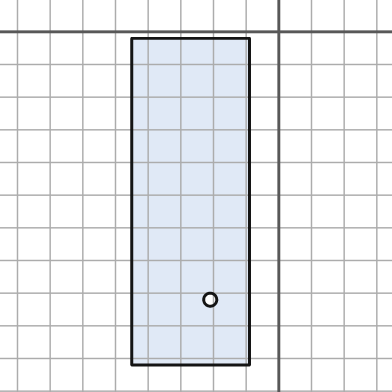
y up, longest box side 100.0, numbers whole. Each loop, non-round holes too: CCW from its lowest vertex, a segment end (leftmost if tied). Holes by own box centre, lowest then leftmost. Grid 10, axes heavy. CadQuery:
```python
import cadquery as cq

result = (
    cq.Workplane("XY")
    .moveTo(-45.0, -102.0)
    .lineTo(-9.0, -102.0)
    .lineTo(-9.0, -2.0)
    .lineTo(-45.0, -2.0)
    .close()
    .moveTo(-21.0, -82.0)
    .circle(2.0)
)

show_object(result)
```